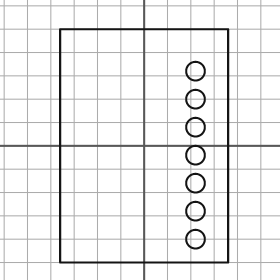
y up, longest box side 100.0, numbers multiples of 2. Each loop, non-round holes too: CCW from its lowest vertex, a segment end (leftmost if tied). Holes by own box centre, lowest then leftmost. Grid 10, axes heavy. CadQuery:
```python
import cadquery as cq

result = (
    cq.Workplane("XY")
    .moveTo(-36.0, -50.0)
    .lineTo(36.0, -50.0)
    .lineTo(36.0, 50.0)
    .lineTo(-36.0, 50.0)
    .close()
    .moveTo(22.0, -40.0)
    .circle(4.0)
    .moveTo(22.0, -28.0)
    .circle(4.0)
    .moveTo(22.0, -16.0)
    .circle(4.0)
    .moveTo(22.0, -4.0)
    .circle(4.0)
    .moveTo(22.0, 8.0)
    .circle(4.0)
    .moveTo(22.0, 20.0)
    .circle(4.0)
    .moveTo(22.0, 32.0)
    .circle(4.0)
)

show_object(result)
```